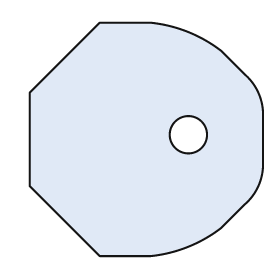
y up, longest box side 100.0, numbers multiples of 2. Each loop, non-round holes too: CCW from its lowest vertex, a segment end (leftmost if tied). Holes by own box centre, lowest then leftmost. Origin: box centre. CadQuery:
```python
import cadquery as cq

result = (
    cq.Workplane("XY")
    .moveTo(-20.0, -50.0)
    .lineTo(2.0, -50.0)
    .threePointArc((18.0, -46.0), (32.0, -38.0))
    .lineTo(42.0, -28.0)
    .threePointArc((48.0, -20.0), (50.0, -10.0))
    .lineTo(50.0, 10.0)
    .threePointArc((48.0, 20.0), (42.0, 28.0))
    .lineTo(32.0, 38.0)
    .threePointArc((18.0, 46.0), (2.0, 50.0))
    .lineTo(-20.0, 50.0)
    .lineTo(-50.0, 20.0)
    .lineTo(-50.0, -20.0)
    .close()
    .moveTo(18.0, 2.0)
    .circle(8.0)
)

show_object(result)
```